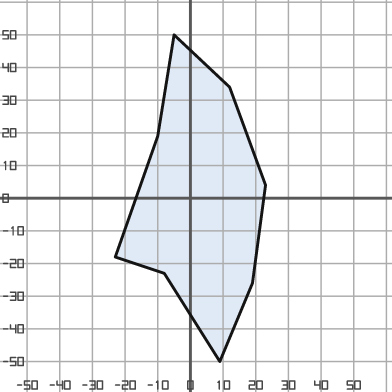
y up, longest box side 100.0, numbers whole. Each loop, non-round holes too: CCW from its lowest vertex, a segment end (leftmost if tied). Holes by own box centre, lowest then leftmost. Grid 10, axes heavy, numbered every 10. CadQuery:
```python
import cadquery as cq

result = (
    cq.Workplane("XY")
    .moveTo(9.0, -50.0)
    .lineTo(19.0, -26.0)
    .lineTo(23.0, 4.0)
    .lineTo(12.0, 34.0)
    .lineTo(-5.0, 50.0)
    .lineTo(-10.0, 19.0)
    .lineTo(-23.0, -18.0)
    .lineTo(-8.0, -23.0)
    .close()
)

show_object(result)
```